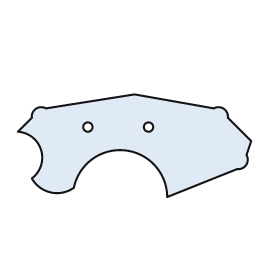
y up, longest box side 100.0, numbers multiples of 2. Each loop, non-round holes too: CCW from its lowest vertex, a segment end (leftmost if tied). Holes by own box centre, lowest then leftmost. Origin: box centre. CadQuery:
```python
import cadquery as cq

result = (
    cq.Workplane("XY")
    .moveTo(14.0, -22.0)
    .lineTo(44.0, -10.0)
    .threePointArc((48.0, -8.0), (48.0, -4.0))
    .lineTo(50.0, 2.0)
    .lineTo(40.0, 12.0)
    .threePointArc((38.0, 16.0), (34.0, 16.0))
    .lineTo(0.0, 22.0)
    .lineTo(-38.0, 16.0)
    .threePointArc((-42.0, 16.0), (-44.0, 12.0))
    .lineTo(-50.0, 6.0)
    .threePointArc((-40.0, -2.0), (-44.0, -14.0))
    .threePointArc((-36.0, -20.0), (-26.0, -18.0))
    .threePointArc((-4.0, -2.0), (14.0, -22.0))
    .close()
    .moveTo(-20.0, 8.0)
    .circle(2.0)
    .moveTo(6.0, 8.0)
    .circle(2.0)
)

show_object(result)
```